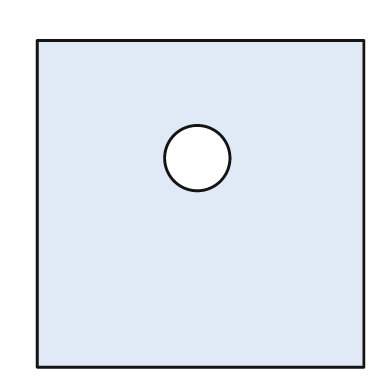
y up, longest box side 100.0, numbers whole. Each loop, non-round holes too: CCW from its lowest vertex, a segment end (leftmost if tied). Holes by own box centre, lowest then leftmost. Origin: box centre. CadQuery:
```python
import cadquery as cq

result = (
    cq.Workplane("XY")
    .moveTo(-50.0, -50.0)
    .lineTo(50.0, -50.0)
    .lineTo(50.0, 50.0)
    .lineTo(-50.0, 50.0)
    .close()
    .moveTo(-1.0, 14.0)
    .circle(10.0)
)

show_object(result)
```